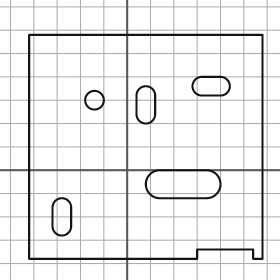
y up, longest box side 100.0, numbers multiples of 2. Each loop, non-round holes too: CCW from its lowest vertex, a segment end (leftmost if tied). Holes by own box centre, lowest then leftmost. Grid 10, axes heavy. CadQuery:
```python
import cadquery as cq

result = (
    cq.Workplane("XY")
    .moveTo(-42.0, -38.0)
    .lineTo(30.0, -38.0)
    .lineTo(30.0, -34.0)
    .lineTo(54.0, -34.0)
    .lineTo(54.0, -38.0)
    .lineTo(58.0, -38.0)
    .lineTo(58.0, 58.0)
    .lineTo(-42.0, 58.0)
    .close()
    .moveTo(-32.0, -24.0)
    .threePointArc((-28.0, -28.0), (-24.0, -24.0))
    .lineTo(-24.0, -16.0)
    .threePointArc((-28.0, -12.0), (-32.0, -16.0))
    .close()
    .moveTo(14.0, -12.0)
    .lineTo(34.0, -12.0)
    .threePointArc((40.0, -6.0), (34.0, 0.0))
    .lineTo(14.0, 0.0)
    .threePointArc((8.0, -6.0), (14.0, -12.0))
    .close()
    .moveTo(4.0, 24.0)
    .threePointArc((8.0, 20.0), (12.0, 24.0))
    .lineTo(12.0, 32.0)
    .threePointArc((8.0, 36.0), (4.0, 32.0))
    .close()
    .moveTo(-14.0, 30.0)
    .circle(4.0)
    .moveTo(32.0, 32.0)
    .lineTo(40.0, 32.0)
    .threePointArc((44.0, 36.0), (40.0, 40.0))
    .lineTo(32.0, 40.0)
    .threePointArc((28.0, 36.0), (32.0, 32.0))
    .close()
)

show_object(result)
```